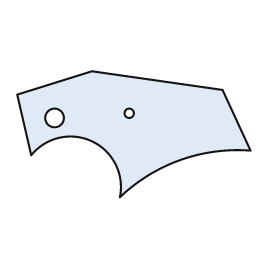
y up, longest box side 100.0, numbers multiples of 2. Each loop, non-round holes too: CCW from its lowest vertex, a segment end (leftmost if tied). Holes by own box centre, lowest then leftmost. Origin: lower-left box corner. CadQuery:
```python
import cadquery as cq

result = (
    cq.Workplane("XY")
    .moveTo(44.0, 0.0)
    .threePointArc((70.0, 16.0), (100.0, 20.0))
    .lineTo(88.0, 46.0)
    .lineTo(32.0, 54.0)
    .lineTo(0.0, 44.0)
    .lineTo(6.0, 18.0)
    .threePointArc((32.0, 24.0), (44.0, 0.0))
    .close()
    .moveTo(16.0, 34.0)
    .circle(4.0)
    .moveTo(48.0, 36.0)
    .circle(2.0)
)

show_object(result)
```